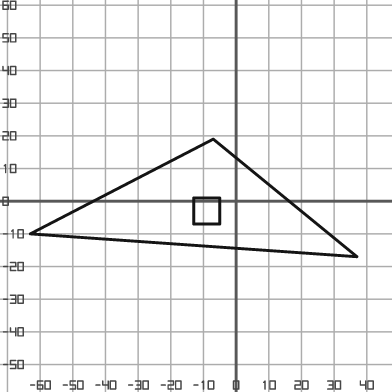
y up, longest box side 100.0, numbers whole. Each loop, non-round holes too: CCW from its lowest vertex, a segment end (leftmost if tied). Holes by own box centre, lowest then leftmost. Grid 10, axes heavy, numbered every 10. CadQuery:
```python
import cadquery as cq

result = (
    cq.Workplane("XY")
    .moveTo(37.0, -17.0)
    .lineTo(-7.0, 19.0)
    .lineTo(-63.0, -10.0)
    .close()
    .moveTo(-13.0, -7.0)
    .lineTo(-5.0, -7.0)
    .lineTo(-5.0, 1.0)
    .lineTo(-13.0, 1.0)
    .close()
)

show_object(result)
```